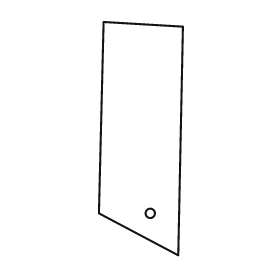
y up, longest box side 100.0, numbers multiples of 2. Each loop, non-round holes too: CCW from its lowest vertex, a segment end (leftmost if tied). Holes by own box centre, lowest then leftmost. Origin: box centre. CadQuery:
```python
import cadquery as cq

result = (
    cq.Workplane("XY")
    .moveTo(16.0, -50.0)
    .lineTo(18.0, 48.0)
    .lineTo(-16.0, 50.0)
    .lineTo(-18.0, -32.0)
    .close()
    .moveTo(4.0, -32.0)
    .circle(2.0)
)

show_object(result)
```